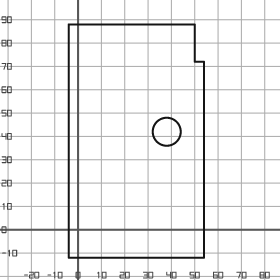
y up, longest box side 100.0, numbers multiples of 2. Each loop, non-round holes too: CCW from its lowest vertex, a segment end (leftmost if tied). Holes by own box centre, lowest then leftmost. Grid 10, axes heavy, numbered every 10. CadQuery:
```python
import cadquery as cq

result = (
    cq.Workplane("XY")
    .moveTo(-4.0, -12.0)
    .lineTo(54.0, -12.0)
    .lineTo(54.0, 72.0)
    .lineTo(50.0, 72.0)
    .lineTo(50.0, 88.0)
    .lineTo(-4.0, 88.0)
    .close()
    .moveTo(38.0, 42.0)
    .circle(6.0)
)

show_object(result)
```